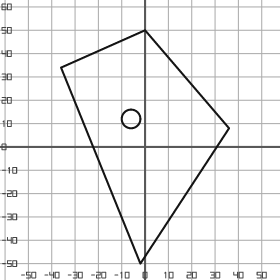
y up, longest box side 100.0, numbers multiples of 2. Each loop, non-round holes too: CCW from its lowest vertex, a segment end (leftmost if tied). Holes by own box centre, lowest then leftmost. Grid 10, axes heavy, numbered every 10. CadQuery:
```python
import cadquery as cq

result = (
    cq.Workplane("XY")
    .moveTo(-2.0, -50.0)
    .lineTo(36.0, 8.0)
    .lineTo(0.0, 50.0)
    .lineTo(-36.0, 34.0)
    .close()
    .moveTo(-6.0, 12.0)
    .circle(4.0)
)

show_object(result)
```